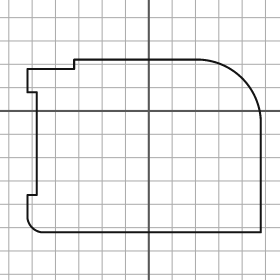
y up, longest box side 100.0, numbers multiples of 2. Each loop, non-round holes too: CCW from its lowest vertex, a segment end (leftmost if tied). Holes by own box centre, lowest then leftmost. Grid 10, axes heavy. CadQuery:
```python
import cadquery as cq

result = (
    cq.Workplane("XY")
    .moveTo(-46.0, -52.0)
    .lineTo(48.0, -52.0)
    .lineTo(48.0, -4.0)
    .threePointArc((40.0, 14.0), (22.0, 22.0))
    .lineTo(-32.0, 22.0)
    .lineTo(-32.0, 18.0)
    .lineTo(-52.0, 18.0)
    .lineTo(-52.0, 8.0)
    .lineTo(-48.0, 8.0)
    .lineTo(-48.0, -36.0)
    .lineTo(-52.0, -36.0)
    .lineTo(-52.0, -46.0)
    .threePointArc((-50.0, -50.0), (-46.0, -52.0))
    .close()
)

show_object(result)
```